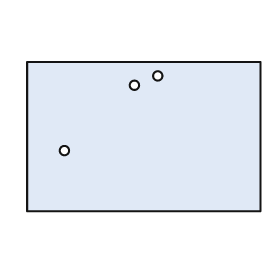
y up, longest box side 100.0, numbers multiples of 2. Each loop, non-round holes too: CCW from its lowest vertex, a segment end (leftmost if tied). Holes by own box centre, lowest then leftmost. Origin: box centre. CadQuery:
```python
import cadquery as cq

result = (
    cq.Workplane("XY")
    .moveTo(-50.0, -32.0)
    .lineTo(50.0, -32.0)
    .lineTo(50.0, 32.0)
    .lineTo(-50.0, 32.0)
    .close()
    .moveTo(-34.0, -6.0)
    .circle(2.0)
    .moveTo(-4.0, 22.0)
    .circle(2.0)
    .moveTo(6.0, 26.0)
    .circle(2.0)
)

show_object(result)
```